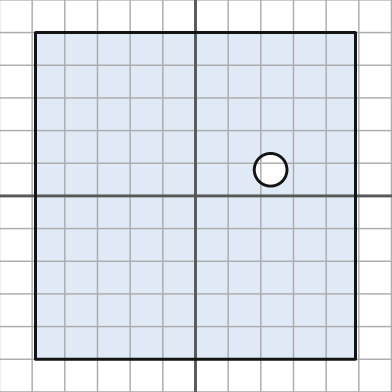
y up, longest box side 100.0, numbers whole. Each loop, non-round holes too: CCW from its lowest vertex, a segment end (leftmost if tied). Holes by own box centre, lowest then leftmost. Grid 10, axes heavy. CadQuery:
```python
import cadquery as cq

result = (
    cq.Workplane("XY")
    .moveTo(-49.0, -50.0)
    .lineTo(49.0, -50.0)
    .lineTo(49.0, 50.0)
    .lineTo(-49.0, 50.0)
    .close()
    .moveTo(23.0, 8.0)
    .circle(5.0)
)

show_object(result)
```